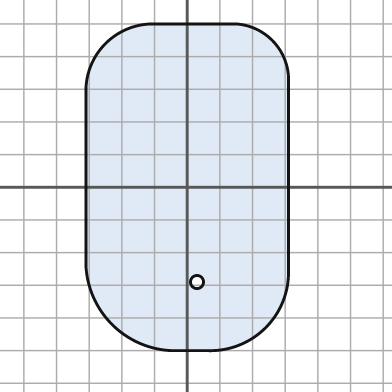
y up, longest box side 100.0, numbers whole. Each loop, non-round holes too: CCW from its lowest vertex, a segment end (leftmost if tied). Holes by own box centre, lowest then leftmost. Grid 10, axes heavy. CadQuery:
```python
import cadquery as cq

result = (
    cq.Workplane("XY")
    .moveTo(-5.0, -50.0)
    .lineTo(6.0, -50.0)
    .threePointArc((24.0, -43.0), (31.0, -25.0))
    .lineTo(31.0, 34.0)
    .threePointArc((26.0, 45.0), (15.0, 50.0))
    .lineTo(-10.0, 50.0)
    .threePointArc((-25.0, 44.0), (-31.0, 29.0))
    .lineTo(-31.0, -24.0)
    .threePointArc((-23.0, -42.0), (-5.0, -50.0))
    .close()
    .moveTo(3.0, -29.0)
    .circle(2.0)
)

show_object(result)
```